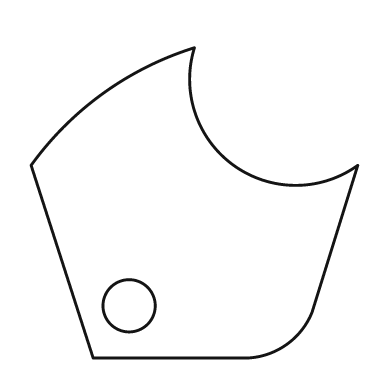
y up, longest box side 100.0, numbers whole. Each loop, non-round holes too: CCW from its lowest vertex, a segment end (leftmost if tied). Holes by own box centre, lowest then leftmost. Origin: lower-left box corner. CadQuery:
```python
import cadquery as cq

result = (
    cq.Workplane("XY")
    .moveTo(19.0, 0.0)
    .lineTo(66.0, 0.0)
    .threePointArc((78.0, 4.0), (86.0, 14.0))
    .lineTo(100.0, 59.0)
    .threePointArc((62.0, 59.0), (50.0, 95.0))
    .threePointArc((22.0, 81.0), (0.0, 59.0))
    .close()
    .moveTo(30.0, 16.0)
    .circle(8.0)
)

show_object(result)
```